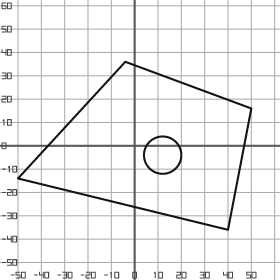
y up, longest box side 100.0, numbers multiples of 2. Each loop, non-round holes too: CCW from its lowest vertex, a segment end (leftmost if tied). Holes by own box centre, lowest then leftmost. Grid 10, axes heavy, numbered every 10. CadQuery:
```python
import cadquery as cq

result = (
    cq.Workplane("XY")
    .moveTo(40.0, -36.0)
    .lineTo(50.0, 16.0)
    .lineTo(-4.0, 36.0)
    .lineTo(-50.0, -14.0)
    .close()
    .moveTo(12.0, -4.0)
    .circle(8.0)
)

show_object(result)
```